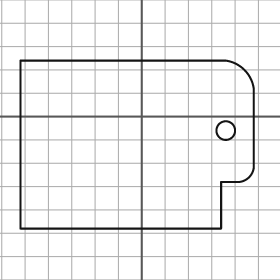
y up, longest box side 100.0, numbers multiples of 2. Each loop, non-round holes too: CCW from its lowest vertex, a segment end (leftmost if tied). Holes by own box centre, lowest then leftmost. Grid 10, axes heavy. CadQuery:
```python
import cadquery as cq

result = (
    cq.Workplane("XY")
    .moveTo(-52.0, -48.0)
    .lineTo(34.0, -48.0)
    .lineTo(34.0, -28.0)
    .lineTo(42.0, -28.0)
    .threePointArc((46.0, -26.0), (48.0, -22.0))
    .lineTo(48.0, 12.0)
    .threePointArc((44.0, 20.0), (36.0, 24.0))
    .lineTo(-52.0, 24.0)
    .close()
    .moveTo(36.0, -6.0)
    .circle(4.0)
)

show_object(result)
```